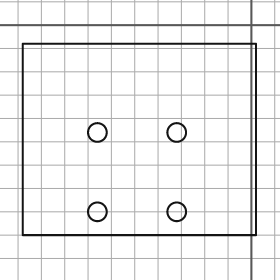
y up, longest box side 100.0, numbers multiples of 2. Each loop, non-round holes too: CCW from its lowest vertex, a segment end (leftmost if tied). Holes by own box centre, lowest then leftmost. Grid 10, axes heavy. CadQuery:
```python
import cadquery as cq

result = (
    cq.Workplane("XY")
    .moveTo(-98.0, -90.0)
    .lineTo(2.0, -90.0)
    .lineTo(2.0, -8.0)
    .lineTo(-98.0, -8.0)
    .close()
    .moveTo(-66.0, -80.0)
    .circle(4.0)
    .moveTo(-32.0, -80.0)
    .circle(4.0)
    .moveTo(-66.0, -46.0)
    .circle(4.0)
    .moveTo(-32.0, -46.0)
    .circle(4.0)
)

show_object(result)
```